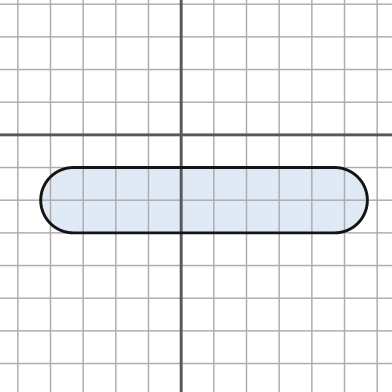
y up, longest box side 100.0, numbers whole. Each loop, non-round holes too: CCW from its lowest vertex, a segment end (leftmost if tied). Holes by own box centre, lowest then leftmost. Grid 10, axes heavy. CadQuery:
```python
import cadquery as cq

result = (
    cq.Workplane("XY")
    .moveTo(-33.0, -30.0)
    .lineTo(47.0, -30.0)
    .threePointArc((57.0, -20.0), (47.0, -10.0))
    .lineTo(-33.0, -10.0)
    .threePointArc((-43.0, -20.0), (-33.0, -30.0))
    .close()
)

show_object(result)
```